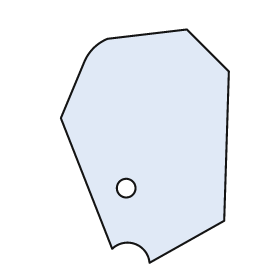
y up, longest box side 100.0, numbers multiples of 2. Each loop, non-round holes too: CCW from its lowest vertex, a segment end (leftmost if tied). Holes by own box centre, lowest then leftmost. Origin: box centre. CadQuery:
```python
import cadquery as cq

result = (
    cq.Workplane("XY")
    .moveTo(2.0, -50.0)
    .lineTo(34.0, -32.0)
    .lineTo(36.0, 32.0)
    .lineTo(18.0, 50.0)
    .lineTo(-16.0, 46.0)
    .threePointArc((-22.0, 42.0), (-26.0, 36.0))
    .lineTo(-36.0, 12.0)
    .lineTo(-14.0, -44.0)
    .threePointArc((-4.0, -42.0), (2.0, -50.0))
    .close()
    .moveTo(-8.0, -18.0)
    .circle(4.0)
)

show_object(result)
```